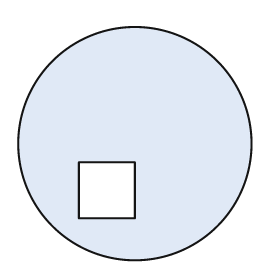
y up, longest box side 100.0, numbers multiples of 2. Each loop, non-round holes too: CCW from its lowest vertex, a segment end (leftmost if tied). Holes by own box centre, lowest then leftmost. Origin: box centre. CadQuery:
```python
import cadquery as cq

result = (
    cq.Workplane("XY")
    .moveTo(0.0, 0.0)
    .circle(50.0)
    .moveTo(-24.0, -32.0)
    .lineTo(0.0, -32.0)
    .lineTo(0.0, -8.0)
    .lineTo(-24.0, -8.0)
    .close()
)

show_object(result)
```